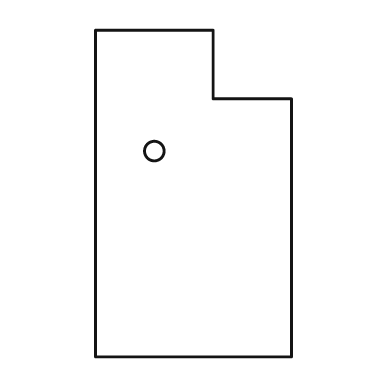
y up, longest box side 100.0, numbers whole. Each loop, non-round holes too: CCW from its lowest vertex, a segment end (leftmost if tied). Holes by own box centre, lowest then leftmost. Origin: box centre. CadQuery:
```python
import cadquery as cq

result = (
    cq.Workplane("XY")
    .moveTo(-30.0, -50.0)
    .lineTo(30.0, -50.0)
    .lineTo(30.0, 29.0)
    .lineTo(6.0, 29.0)
    .lineTo(6.0, 50.0)
    .lineTo(-30.0, 50.0)
    .close()
    .moveTo(-12.0, 13.0)
    .circle(3.0)
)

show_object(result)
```